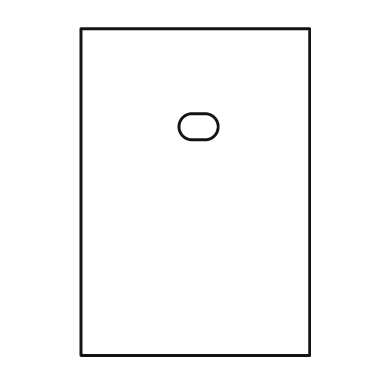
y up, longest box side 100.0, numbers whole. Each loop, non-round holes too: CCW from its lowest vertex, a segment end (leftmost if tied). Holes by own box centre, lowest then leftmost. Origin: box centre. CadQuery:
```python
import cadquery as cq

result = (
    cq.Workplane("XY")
    .moveTo(-35.0, -50.0)
    .lineTo(35.0, -50.0)
    .lineTo(35.0, 50.0)
    .lineTo(-35.0, 50.0)
    .close()
    .moveTo(-1.0, 16.0)
    .lineTo(3.0, 16.0)
    .threePointArc((7.0, 20.0), (3.0, 24.0))
    .lineTo(-1.0, 24.0)
    .threePointArc((-5.0, 20.0), (-1.0, 16.0))
    .close()
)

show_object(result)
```